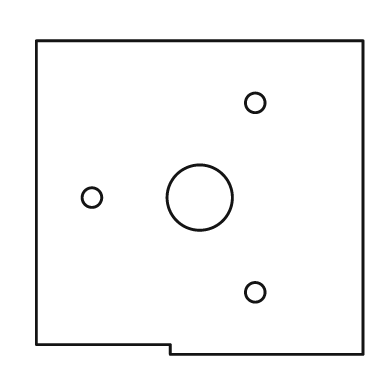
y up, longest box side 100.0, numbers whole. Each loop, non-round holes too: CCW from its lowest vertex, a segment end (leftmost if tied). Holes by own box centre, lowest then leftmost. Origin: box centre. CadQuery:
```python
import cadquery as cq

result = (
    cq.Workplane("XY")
    .moveTo(-9.0, -48.0)
    .lineTo(50.0, -48.0)
    .lineTo(50.0, 48.0)
    .lineTo(-50.0, 48.0)
    .lineTo(-50.0, -45.0)
    .lineTo(-9.0, -45.0)
    .close()
    .moveTo(17.0, -29.0)
    .circle(3.0)
    .moveTo(-33.0, 0.0)
    .circle(3.0)
    .moveTo(0.0, 0.0)
    .circle(10.0)
    .moveTo(17.0, 29.0)
    .circle(3.0)
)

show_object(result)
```